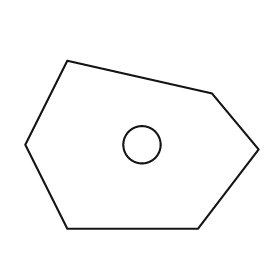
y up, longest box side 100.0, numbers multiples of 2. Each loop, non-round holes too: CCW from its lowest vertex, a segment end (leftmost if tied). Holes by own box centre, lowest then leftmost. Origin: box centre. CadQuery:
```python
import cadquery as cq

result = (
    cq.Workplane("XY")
    .moveTo(-32.0, -36.0)
    .lineTo(24.0, -36.0)
    .lineTo(50.0, -2.0)
    .lineTo(30.0, 22.0)
    .lineTo(-32.0, 36.0)
    .lineTo(-50.0, 0.0)
    .close()
    .moveTo(0.0, 0.0)
    .circle(8.0)
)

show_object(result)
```